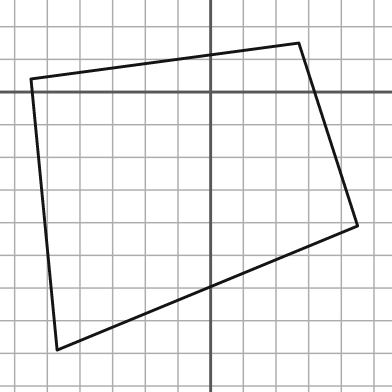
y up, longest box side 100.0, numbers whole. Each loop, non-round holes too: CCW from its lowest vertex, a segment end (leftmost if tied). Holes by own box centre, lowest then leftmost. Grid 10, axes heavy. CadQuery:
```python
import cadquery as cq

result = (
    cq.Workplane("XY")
    .moveTo(-47.0, -79.0)
    .lineTo(45.0, -41.0)
    .lineTo(27.0, 15.0)
    .lineTo(-55.0, 4.0)
    .close()
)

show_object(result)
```